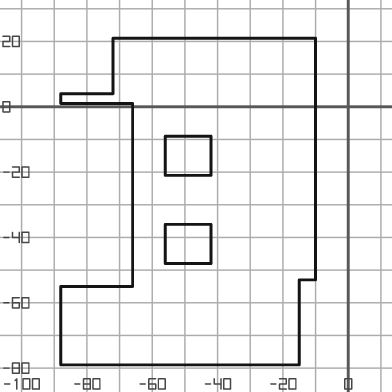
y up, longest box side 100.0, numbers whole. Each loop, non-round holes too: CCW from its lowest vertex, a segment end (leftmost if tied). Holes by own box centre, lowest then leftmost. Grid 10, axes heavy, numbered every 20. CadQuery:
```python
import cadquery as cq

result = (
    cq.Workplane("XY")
    .moveTo(-88.0, -79.0)
    .lineTo(-15.0, -79.0)
    .lineTo(-15.0, -53.0)
    .lineTo(-10.0, -53.0)
    .lineTo(-10.0, 21.0)
    .lineTo(-72.0, 21.0)
    .lineTo(-72.0, 4.0)
    .lineTo(-88.0, 4.0)
    .lineTo(-88.0, 1.0)
    .lineTo(-66.0, 1.0)
    .lineTo(-66.0, -55.0)
    .lineTo(-88.0, -55.0)
    .close()
    .moveTo(-56.0, -48.0)
    .lineTo(-42.0, -48.0)
    .lineTo(-42.0, -36.0)
    .lineTo(-56.0, -36.0)
    .close()
    .moveTo(-56.0, -21.0)
    .lineTo(-42.0, -21.0)
    .lineTo(-42.0, -9.0)
    .lineTo(-56.0, -9.0)
    .close()
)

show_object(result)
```